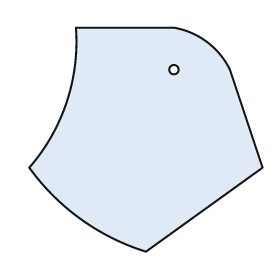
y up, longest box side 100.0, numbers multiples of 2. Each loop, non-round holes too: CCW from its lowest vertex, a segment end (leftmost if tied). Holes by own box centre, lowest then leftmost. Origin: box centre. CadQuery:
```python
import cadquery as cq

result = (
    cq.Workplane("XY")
    .moveTo(0.0, -48.0)
    .lineTo(50.0, -12.0)
    .lineTo(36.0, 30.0)
    .threePointArc((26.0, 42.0), (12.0, 48.0))
    .lineTo(-30.0, 48.0)
    .threePointArc((-34.0, 16.0), (-50.0, -12.0))
    .threePointArc((-28.0, -34.0), (0.0, -48.0))
    .close()
    .moveTo(12.0, 30.0)
    .circle(2.0)
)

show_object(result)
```